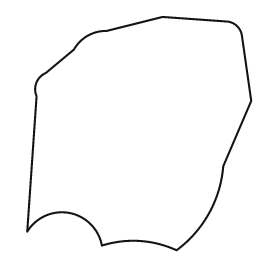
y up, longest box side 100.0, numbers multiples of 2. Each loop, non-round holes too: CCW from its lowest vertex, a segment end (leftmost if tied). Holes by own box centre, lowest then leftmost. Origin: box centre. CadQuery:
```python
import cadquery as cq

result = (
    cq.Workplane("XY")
    .moveTo(16.0, -50.0)
    .threePointArc((30.0, -34.0), (36.0, -14.0))
    .lineTo(48.0, 14.0)
    .lineTo(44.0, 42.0)
    .threePointArc((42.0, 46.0), (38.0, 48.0))
    .lineTo(10.0, 50.0)
    .lineTo(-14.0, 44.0)
    .threePointArc((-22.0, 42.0), (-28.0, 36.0))
    .lineTo(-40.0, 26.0)
    .threePointArc((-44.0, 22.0), (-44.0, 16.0))
    .lineTo(-48.0, -42.0)
    .threePointArc((-30.0, -34.0), (-16.0, -48.0))
    .threePointArc((0.0, -46.0), (16.0, -50.0))
    .close()
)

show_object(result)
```